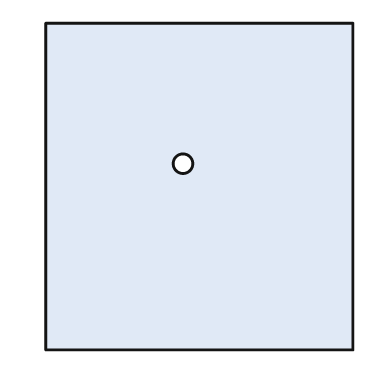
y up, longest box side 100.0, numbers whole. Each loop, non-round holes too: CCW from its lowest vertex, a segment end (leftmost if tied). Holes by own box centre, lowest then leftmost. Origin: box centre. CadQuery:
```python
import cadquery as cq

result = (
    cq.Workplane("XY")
    .moveTo(-47.0, -50.0)
    .lineTo(47.0, -50.0)
    .lineTo(47.0, 50.0)
    .lineTo(-47.0, 50.0)
    .close()
    .moveTo(-5.0, 7.0)
    .circle(3.0)
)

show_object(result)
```